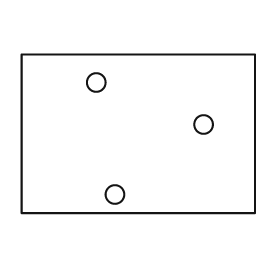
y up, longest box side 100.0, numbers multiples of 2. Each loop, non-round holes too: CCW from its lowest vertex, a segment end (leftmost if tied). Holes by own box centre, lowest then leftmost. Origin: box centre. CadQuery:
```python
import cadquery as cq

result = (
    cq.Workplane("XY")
    .moveTo(-50.0, -34.0)
    .lineTo(50.0, -34.0)
    .lineTo(50.0, 34.0)
    .lineTo(-50.0, 34.0)
    .close()
    .moveTo(-10.0, -26.0)
    .circle(4.0)
    .moveTo(28.0, 4.0)
    .circle(4.0)
    .moveTo(-18.0, 22.0)
    .circle(4.0)
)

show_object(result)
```